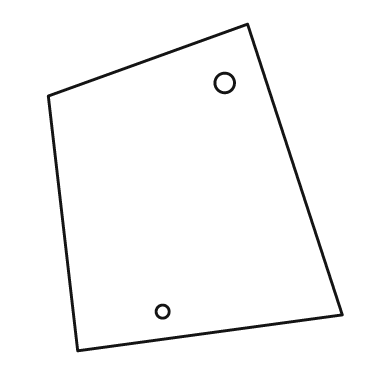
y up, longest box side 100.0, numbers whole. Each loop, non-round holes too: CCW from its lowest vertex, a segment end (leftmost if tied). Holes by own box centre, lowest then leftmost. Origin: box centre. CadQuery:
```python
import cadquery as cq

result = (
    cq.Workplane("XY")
    .moveTo(-36.0, -50.0)
    .lineTo(45.0, -39.0)
    .lineTo(16.0, 50.0)
    .lineTo(-45.0, 28.0)
    .close()
    .moveTo(-10.0, -38.0)
    .circle(2.0)
    .moveTo(9.0, 32.0)
    .circle(3.0)
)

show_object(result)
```